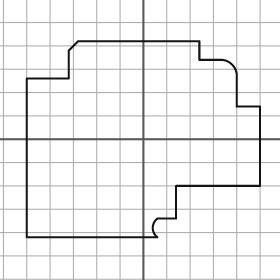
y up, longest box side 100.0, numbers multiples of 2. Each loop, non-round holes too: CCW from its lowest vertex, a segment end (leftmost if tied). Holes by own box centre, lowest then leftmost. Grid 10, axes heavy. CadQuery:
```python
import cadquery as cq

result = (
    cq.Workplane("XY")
    .moveTo(-50.0, -42.0)
    .lineTo(6.0, -42.0)
    .threePointArc((4.0, -38.0), (6.0, -34.0))
    .lineTo(14.0, -34.0)
    .lineTo(14.0, -20.0)
    .lineTo(50.0, -20.0)
    .lineTo(50.0, 14.0)
    .lineTo(40.0, 14.0)
    .lineTo(40.0, 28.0)
    .threePointArc((38.0, 32.0), (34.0, 34.0))
    .lineTo(24.0, 34.0)
    .lineTo(24.0, 42.0)
    .lineTo(-28.0, 42.0)
    .lineTo(-32.0, 38.0)
    .lineTo(-32.0, 26.0)
    .lineTo(-50.0, 26.0)
    .close()
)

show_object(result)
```